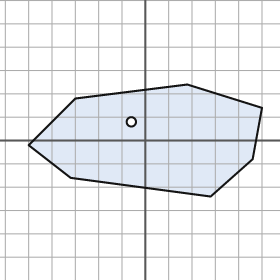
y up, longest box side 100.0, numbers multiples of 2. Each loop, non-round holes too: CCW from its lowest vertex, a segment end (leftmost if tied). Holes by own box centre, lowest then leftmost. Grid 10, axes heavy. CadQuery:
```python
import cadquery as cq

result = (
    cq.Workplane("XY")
    .moveTo(28.0, -24.0)
    .lineTo(46.0, -8.0)
    .lineTo(50.0, 14.0)
    .lineTo(18.0, 24.0)
    .lineTo(-30.0, 18.0)
    .lineTo(-50.0, -2.0)
    .lineTo(-32.0, -16.0)
    .close()
    .moveTo(-6.0, 8.0)
    .circle(2.0)
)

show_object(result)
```